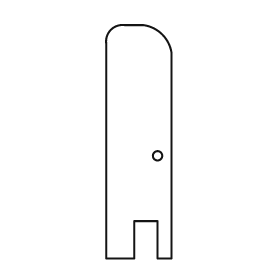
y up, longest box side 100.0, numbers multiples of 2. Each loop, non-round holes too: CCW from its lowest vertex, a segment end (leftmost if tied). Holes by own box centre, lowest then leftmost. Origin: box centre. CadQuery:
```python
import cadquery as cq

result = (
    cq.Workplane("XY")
    .moveTo(-14.0, -50.0)
    .lineTo(-2.0, -50.0)
    .lineTo(-2.0, -34.0)
    .lineTo(8.0, -34.0)
    .lineTo(8.0, -50.0)
    .lineTo(14.0, -50.0)
    .lineTo(14.0, 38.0)
    .threePointArc((10.0, 46.0), (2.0, 50.0))
    .lineTo(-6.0, 50.0)
    .threePointArc((-12.0, 48.0), (-14.0, 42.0))
    .close()
    .moveTo(8.0, -6.0)
    .circle(2.0)
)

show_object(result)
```